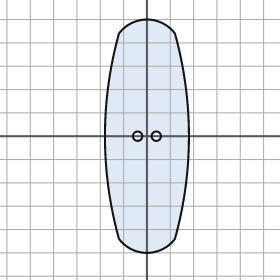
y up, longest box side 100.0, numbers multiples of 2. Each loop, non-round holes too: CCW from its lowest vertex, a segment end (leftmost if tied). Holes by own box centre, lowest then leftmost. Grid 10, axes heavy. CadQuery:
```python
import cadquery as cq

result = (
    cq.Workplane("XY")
    .moveTo(-12.0, -44.0)
    .threePointArc((0.0, -50.0), (12.0, -44.0))
    .threePointArc((18.0, 0.0), (12.0, 44.0))
    .threePointArc((0.0, 50.0), (-12.0, 44.0))
    .threePointArc((-18.0, 0.0), (-12.0, -44.0))
    .close()
    .moveTo(-4.0, 0.0)
    .circle(2.0)
    .moveTo(4.0, 0.0)
    .circle(2.0)
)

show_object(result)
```